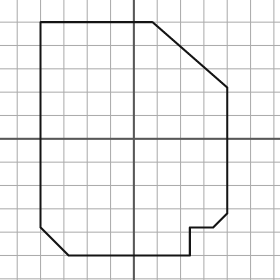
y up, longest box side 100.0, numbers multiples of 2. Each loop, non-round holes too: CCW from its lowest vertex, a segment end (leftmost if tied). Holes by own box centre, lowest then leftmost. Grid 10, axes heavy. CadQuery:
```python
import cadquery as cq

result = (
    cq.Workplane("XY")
    .moveTo(-28.0, -50.0)
    .lineTo(24.0, -50.0)
    .lineTo(24.0, -38.0)
    .lineTo(34.0, -38.0)
    .lineTo(40.0, -32.0)
    .lineTo(40.0, 22.0)
    .lineTo(8.0, 50.0)
    .lineTo(-40.0, 50.0)
    .lineTo(-40.0, -38.0)
    .close()
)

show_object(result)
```